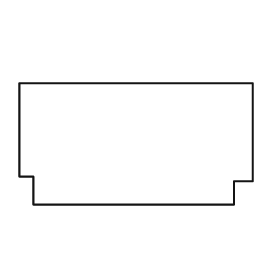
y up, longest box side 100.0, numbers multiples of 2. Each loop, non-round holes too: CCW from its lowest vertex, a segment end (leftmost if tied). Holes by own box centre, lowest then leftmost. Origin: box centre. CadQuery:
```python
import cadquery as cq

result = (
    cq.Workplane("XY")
    .moveTo(-44.0, -26.0)
    .lineTo(42.0, -26.0)
    .lineTo(42.0, -16.0)
    .lineTo(50.0, -16.0)
    .lineTo(50.0, 26.0)
    .lineTo(-50.0, 26.0)
    .lineTo(-50.0, -14.0)
    .lineTo(-44.0, -14.0)
    .close()
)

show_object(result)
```